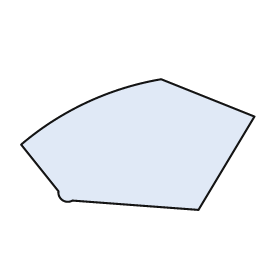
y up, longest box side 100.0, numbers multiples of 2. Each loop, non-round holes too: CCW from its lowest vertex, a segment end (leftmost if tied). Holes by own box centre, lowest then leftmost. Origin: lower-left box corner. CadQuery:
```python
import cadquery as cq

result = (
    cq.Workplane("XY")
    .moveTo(76.0, 0.0)
    .lineTo(100.0, 40.0)
    .lineTo(60.0, 56.0)
    .threePointArc((28.0, 46.0), (0.0, 28.0))
    .lineTo(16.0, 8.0)
    .threePointArc((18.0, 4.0), (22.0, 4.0))
    .close()
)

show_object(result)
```